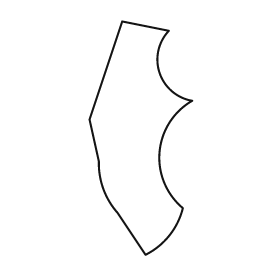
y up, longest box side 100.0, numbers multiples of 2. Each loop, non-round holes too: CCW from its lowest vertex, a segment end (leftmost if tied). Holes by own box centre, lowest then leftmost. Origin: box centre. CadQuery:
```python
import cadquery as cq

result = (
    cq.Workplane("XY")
    .moveTo(2.0, -50.0)
    .threePointArc((12.0, -42.0), (18.0, -30.0))
    .threePointArc((8.0, -6.0), (22.0, 16.0))
    .threePointArc((8.0, 28.0), (12.0, 46.0))
    .lineTo(-8.0, 50.0)
    .lineTo(-22.0, 8.0)
    .lineTo(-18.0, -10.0)
    .threePointArc((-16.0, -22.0), (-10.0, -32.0))
    .close()
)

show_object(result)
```